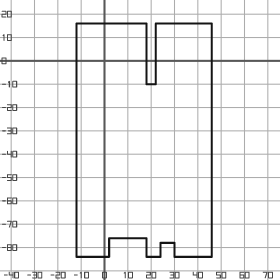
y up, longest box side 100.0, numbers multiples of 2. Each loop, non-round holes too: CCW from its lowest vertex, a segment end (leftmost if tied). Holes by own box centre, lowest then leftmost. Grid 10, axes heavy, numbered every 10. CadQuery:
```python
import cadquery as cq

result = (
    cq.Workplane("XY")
    .moveTo(-12.0, -84.0)
    .lineTo(2.0, -84.0)
    .lineTo(2.0, -76.0)
    .lineTo(18.0, -76.0)
    .lineTo(18.0, -84.0)
    .lineTo(24.0, -84.0)
    .lineTo(24.0, -78.0)
    .lineTo(30.0, -78.0)
    .lineTo(30.0, -84.0)
    .lineTo(46.0, -84.0)
    .lineTo(46.0, 16.0)
    .lineTo(22.0, 16.0)
    .lineTo(22.0, -10.0)
    .lineTo(18.0, -10.0)
    .lineTo(18.0, 16.0)
    .lineTo(-12.0, 16.0)
    .close()
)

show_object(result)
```